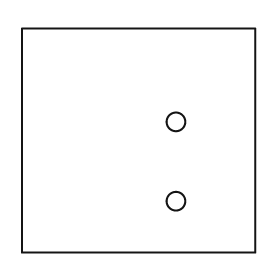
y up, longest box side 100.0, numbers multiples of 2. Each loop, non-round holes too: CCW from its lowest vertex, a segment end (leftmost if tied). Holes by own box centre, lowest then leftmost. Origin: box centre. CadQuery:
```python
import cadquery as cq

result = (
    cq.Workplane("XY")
    .moveTo(-50.0, -48.0)
    .lineTo(50.0, -48.0)
    .lineTo(50.0, 48.0)
    .lineTo(-50.0, 48.0)
    .close()
    .moveTo(16.0, -26.0)
    .circle(4.0)
    .moveTo(16.0, 8.0)
    .circle(4.0)
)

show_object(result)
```